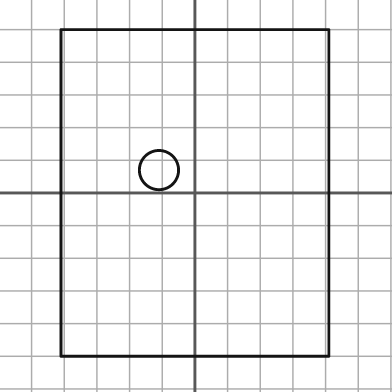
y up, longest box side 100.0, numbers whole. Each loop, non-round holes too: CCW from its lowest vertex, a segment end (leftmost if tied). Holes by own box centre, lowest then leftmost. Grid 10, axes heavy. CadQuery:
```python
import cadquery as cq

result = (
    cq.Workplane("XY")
    .moveTo(-41.0, -50.0)
    .lineTo(41.0, -50.0)
    .lineTo(41.0, 50.0)
    .lineTo(-41.0, 50.0)
    .close()
    .moveTo(-11.0, 7.0)
    .circle(6.0)
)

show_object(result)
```